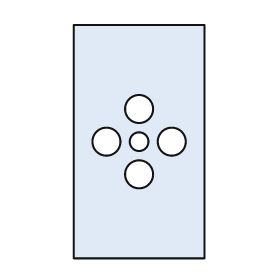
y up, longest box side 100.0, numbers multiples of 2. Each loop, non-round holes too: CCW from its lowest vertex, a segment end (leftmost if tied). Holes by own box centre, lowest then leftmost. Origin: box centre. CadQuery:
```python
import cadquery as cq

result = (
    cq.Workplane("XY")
    .moveTo(-28.0, -50.0)
    .lineTo(28.0, -50.0)
    .lineTo(28.0, 50.0)
    .lineTo(-28.0, 50.0)
    .close()
    .moveTo(0.0, -14.0)
    .circle(6.0)
    .moveTo(-14.0, 0.0)
    .circle(6.0)
    .moveTo(0.0, 0.0)
    .circle(4.0)
    .moveTo(14.0, 0.0)
    .circle(6.0)
    .moveTo(0.0, 14.0)
    .circle(6.0)
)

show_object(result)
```